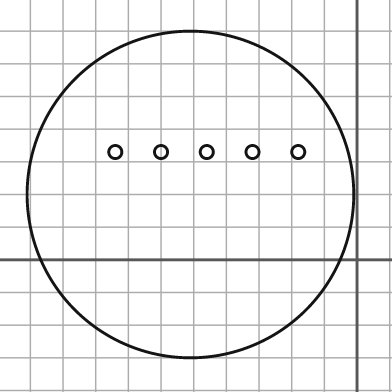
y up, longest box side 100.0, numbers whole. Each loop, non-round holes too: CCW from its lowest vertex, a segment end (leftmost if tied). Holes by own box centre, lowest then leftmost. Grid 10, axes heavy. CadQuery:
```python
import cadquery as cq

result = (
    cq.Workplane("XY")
    .moveTo(-51.0, 20.0)
    .circle(50.0)
    .moveTo(-74.0, 33.0)
    .circle(2.0)
    .moveTo(-60.0, 33.0)
    .circle(2.0)
    .moveTo(-46.0, 33.0)
    .circle(2.0)
    .moveTo(-32.0, 33.0)
    .circle(2.0)
    .moveTo(-18.0, 33.0)
    .circle(2.0)
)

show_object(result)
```